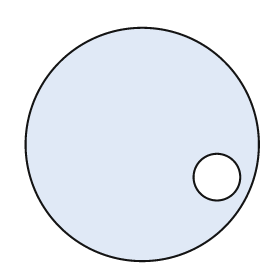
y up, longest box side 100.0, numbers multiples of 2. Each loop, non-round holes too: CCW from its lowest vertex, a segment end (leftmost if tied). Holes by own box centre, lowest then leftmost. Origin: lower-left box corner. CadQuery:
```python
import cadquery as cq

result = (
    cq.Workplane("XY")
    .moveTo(50.0, 50.0)
    .circle(50.0)
    .moveTo(82.0, 36.0)
    .circle(10.0)
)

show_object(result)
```